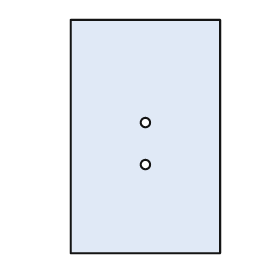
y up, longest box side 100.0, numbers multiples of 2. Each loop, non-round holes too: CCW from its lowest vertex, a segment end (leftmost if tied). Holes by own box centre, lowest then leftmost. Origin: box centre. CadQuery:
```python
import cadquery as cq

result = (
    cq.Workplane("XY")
    .moveTo(-32.0, -50.0)
    .lineTo(32.0, -50.0)
    .lineTo(32.0, 50.0)
    .lineTo(-32.0, 50.0)
    .close()
    .moveTo(0.0, -12.0)
    .circle(2.0)
    .moveTo(0.0, 6.0)
    .circle(2.0)
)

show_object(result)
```